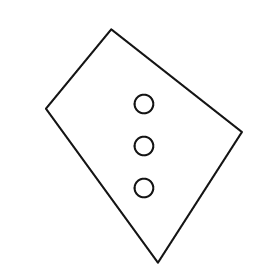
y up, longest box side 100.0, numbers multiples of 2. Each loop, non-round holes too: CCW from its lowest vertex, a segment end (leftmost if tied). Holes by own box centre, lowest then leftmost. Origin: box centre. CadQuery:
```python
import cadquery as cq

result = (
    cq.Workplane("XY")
    .moveTo(6.0, -50.0)
    .lineTo(42.0, 6.0)
    .lineTo(-14.0, 50.0)
    .lineTo(-42.0, 16.0)
    .close()
    .moveTo(0.0, -18.0)
    .circle(4.0)
    .moveTo(0.0, 0.0)
    .circle(4.0)
    .moveTo(0.0, 18.0)
    .circle(4.0)
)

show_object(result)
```